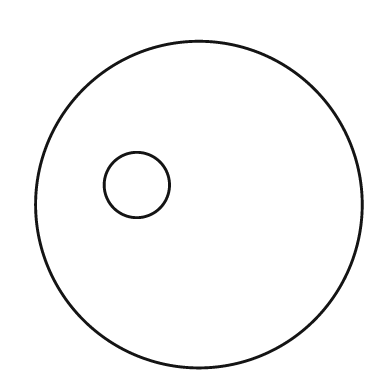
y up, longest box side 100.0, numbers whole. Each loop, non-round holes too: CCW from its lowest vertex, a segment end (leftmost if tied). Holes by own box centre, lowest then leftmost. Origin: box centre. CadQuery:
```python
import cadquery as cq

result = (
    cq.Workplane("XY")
    .moveTo(0.0, 0.0)
    .circle(50.0)
    .moveTo(-19.0, 6.0)
    .circle(10.0)
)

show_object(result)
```